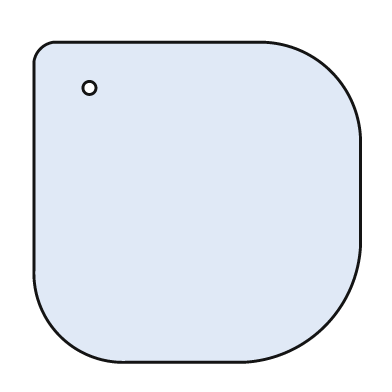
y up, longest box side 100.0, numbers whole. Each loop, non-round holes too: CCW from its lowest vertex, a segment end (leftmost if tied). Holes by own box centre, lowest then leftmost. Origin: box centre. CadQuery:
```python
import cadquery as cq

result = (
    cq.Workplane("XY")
    .moveTo(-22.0, -49.0)
    .lineTo(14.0, -49.0)
    .threePointArc((39.0, -38.0), (50.0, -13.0))
    .lineTo(50.0, 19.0)
    .threePointArc((41.0, 40.0), (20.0, 49.0))
    .lineTo(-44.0, 49.0)
    .threePointArc((-48.0, 47.0), (-50.0, 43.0))
    .lineTo(-50.0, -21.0)
    .threePointArc((-42.0, -41.0), (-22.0, -49.0))
    .close()
    .moveTo(-33.0, 35.0)
    .circle(2.0)
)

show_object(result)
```